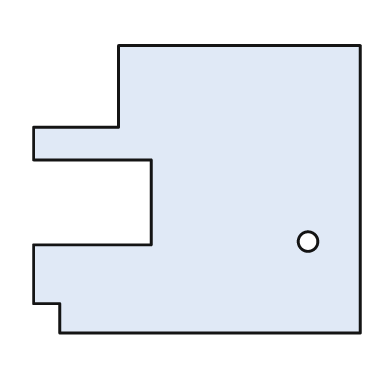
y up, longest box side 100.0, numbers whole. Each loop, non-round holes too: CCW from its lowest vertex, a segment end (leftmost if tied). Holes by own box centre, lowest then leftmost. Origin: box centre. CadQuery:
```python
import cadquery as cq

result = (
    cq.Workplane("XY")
    .moveTo(-42.0, -44.0)
    .lineTo(50.0, -44.0)
    .lineTo(50.0, 44.0)
    .lineTo(-24.0, 44.0)
    .lineTo(-24.0, 19.0)
    .lineTo(-50.0, 19.0)
    .lineTo(-50.0, 9.0)
    .lineTo(-14.0, 9.0)
    .lineTo(-14.0, -17.0)
    .lineTo(-50.0, -17.0)
    .lineTo(-50.0, -35.0)
    .lineTo(-42.0, -35.0)
    .close()
    .moveTo(34.0, -16.0)
    .circle(3.0)
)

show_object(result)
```